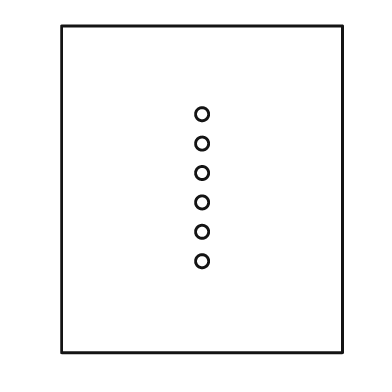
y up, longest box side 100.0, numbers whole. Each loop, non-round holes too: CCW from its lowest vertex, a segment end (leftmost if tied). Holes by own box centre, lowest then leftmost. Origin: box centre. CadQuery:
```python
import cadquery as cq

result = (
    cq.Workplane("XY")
    .moveTo(-43.0, -50.0)
    .lineTo(43.0, -50.0)
    .lineTo(43.0, 50.0)
    .lineTo(-43.0, 50.0)
    .close()
    .moveTo(0.0, -22.0)
    .circle(2.0)
    .moveTo(0.0, -13.0)
    .circle(2.0)
    .moveTo(0.0, -4.0)
    .circle(2.0)
    .moveTo(0.0, 5.0)
    .circle(2.0)
    .moveTo(0.0, 14.0)
    .circle(2.0)
    .moveTo(0.0, 23.0)
    .circle(2.0)
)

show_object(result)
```